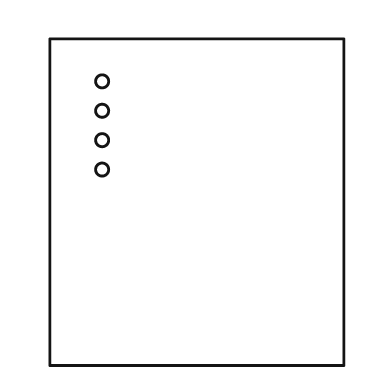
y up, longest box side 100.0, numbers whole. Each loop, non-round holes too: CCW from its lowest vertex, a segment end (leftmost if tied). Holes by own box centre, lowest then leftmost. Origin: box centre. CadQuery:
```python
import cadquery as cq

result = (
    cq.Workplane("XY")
    .moveTo(-45.0, -50.0)
    .lineTo(45.0, -50.0)
    .lineTo(45.0, 50.0)
    .lineTo(-45.0, 50.0)
    .close()
    .moveTo(-29.0, 10.0)
    .circle(2.0)
    .moveTo(-29.0, 19.0)
    .circle(2.0)
    .moveTo(-29.0, 28.0)
    .circle(2.0)
    .moveTo(-29.0, 37.0)
    .circle(2.0)
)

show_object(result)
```